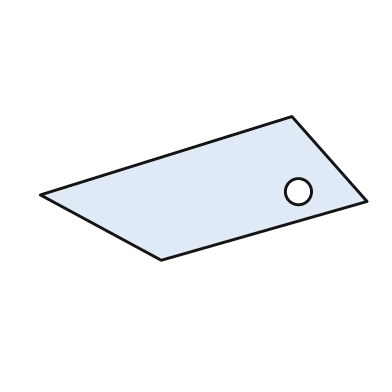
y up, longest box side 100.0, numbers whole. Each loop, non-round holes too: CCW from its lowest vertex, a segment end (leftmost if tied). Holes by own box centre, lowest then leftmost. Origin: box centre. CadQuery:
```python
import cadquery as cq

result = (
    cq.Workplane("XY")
    .moveTo(-13.0, -22.0)
    .lineTo(50.0, -4.0)
    .lineTo(27.0, 22.0)
    .lineTo(-50.0, -2.0)
    .close()
    .moveTo(29.0, -1.0)
    .circle(4.0)
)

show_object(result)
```